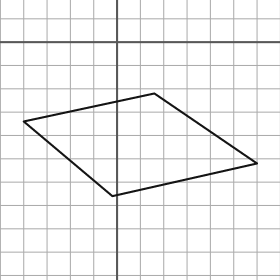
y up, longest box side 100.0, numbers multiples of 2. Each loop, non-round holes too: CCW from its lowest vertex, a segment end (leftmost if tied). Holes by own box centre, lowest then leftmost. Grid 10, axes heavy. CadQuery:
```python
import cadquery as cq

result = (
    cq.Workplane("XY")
    .moveTo(-2.0, -66.0)
    .lineTo(60.0, -52.0)
    .lineTo(16.0, -22.0)
    .lineTo(-40.0, -34.0)
    .close()
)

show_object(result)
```